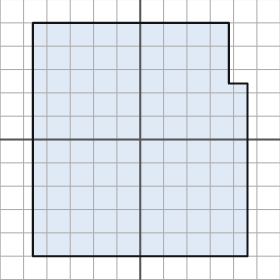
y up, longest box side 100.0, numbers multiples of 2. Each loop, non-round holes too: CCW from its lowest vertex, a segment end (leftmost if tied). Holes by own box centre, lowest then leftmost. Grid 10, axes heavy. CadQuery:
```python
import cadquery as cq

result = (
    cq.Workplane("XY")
    .moveTo(-46.0, -50.0)
    .lineTo(46.0, -50.0)
    .lineTo(46.0, 24.0)
    .lineTo(38.0, 24.0)
    .lineTo(38.0, 50.0)
    .lineTo(-46.0, 50.0)
    .close()
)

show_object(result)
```